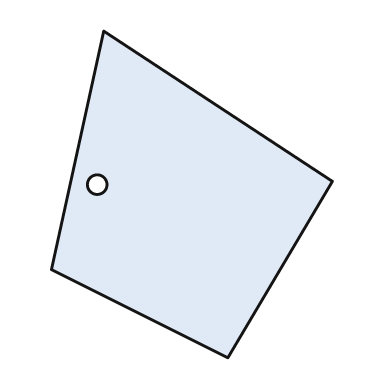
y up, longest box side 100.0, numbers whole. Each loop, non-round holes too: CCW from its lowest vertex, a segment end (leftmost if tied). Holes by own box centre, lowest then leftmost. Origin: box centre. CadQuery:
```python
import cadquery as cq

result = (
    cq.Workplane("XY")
    .moveTo(11.0, -50.0)
    .lineTo(43.0, 4.0)
    .lineTo(-27.0, 50.0)
    .lineTo(-43.0, -23.0)
    .close()
    .moveTo(-29.0, 3.0)
    .circle(3.0)
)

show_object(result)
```